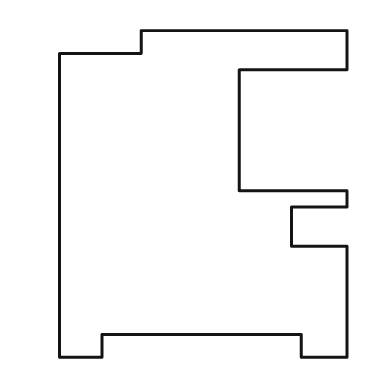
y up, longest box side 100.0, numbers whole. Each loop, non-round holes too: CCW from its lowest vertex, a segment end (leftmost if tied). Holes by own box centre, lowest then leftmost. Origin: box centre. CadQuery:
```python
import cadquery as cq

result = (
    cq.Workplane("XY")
    .moveTo(-44.0, -50.0)
    .lineTo(-31.0, -50.0)
    .lineTo(-31.0, -43.0)
    .lineTo(30.0, -43.0)
    .lineTo(30.0, -50.0)
    .lineTo(44.0, -50.0)
    .lineTo(44.0, -16.0)
    .lineTo(27.0, -16.0)
    .lineTo(27.0, -4.0)
    .lineTo(44.0, -4.0)
    .lineTo(44.0, 1.0)
    .lineTo(11.0, 1.0)
    .lineTo(11.0, 38.0)
    .lineTo(44.0, 38.0)
    .lineTo(44.0, 50.0)
    .lineTo(-19.0, 50.0)
    .lineTo(-19.0, 43.0)
    .lineTo(-44.0, 43.0)
    .close()
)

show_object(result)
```